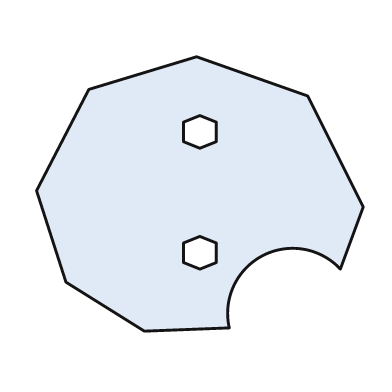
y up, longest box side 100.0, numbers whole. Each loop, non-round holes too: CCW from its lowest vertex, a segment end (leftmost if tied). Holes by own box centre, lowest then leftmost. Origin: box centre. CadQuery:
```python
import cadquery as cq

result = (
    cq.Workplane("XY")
    .moveTo(-17.0, -42.0)
    .lineTo(9.0, -41.0)
    .threePointArc((19.0, -19.0), (43.0, -23.0))
    .lineTo(50.0, -4.0)
    .lineTo(33.0, 30.0)
    .lineTo(-1.0, 42.0)
    .lineTo(-34.0, 32.0)
    .lineTo(-50.0, 1.0)
    .lineTo(-41.0, -27.0)
    .close()
    .moveTo(0.0, -23.0)
    .lineTo(5.0, -21.0)
    .lineTo(5.0, -15.0)
    .lineTo(0.0, -13.0)
    .lineTo(-5.0, -15.0)
    .lineTo(-5.0, -21.0)
    .close()
    .moveTo(0.0, 14.0)
    .lineTo(5.0, 16.0)
    .lineTo(5.0, 22.0)
    .lineTo(0.0, 24.0)
    .lineTo(-5.0, 22.0)
    .lineTo(-5.0, 16.0)
    .close()
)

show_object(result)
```